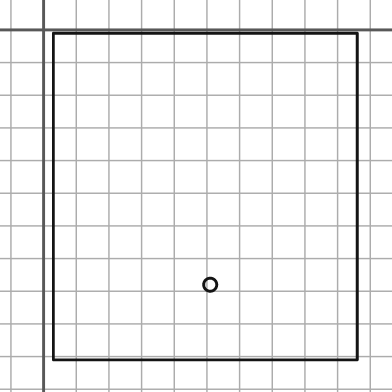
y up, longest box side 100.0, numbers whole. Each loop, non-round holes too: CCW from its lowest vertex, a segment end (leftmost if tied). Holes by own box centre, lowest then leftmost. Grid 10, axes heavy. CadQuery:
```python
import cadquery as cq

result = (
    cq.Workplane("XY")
    .moveTo(3.0, -101.0)
    .lineTo(96.0, -101.0)
    .lineTo(96.0, -1.0)
    .lineTo(3.0, -1.0)
    .close()
    .moveTo(51.0, -78.0)
    .circle(2.0)
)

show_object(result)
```